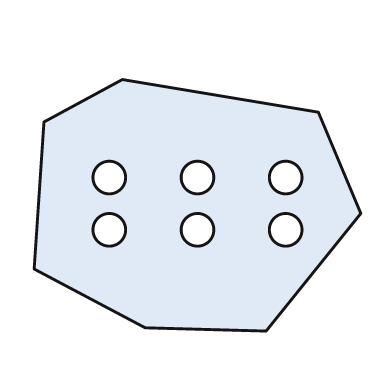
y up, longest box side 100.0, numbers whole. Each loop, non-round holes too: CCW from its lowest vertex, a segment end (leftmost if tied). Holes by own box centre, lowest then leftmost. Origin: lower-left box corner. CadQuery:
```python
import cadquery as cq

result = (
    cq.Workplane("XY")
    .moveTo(71.0, 0.0)
    .lineTo(100.0, 36.0)
    .lineTo(87.0, 67.0)
    .lineTo(27.0, 77.0)
    .lineTo(3.0, 64.0)
    .lineTo(0.0, 19.0)
    .lineTo(34.0, 1.0)
    .close()
    .moveTo(23.0, 31.0)
    .circle(5.0)
    .moveTo(50.0, 31.0)
    .circle(5.0)
    .moveTo(77.0, 31.0)
    .circle(5.0)
    .moveTo(23.0, 47.0)
    .circle(5.0)
    .moveTo(50.0, 47.0)
    .circle(5.0)
    .moveTo(77.0, 47.0)
    .circle(5.0)
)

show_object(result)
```